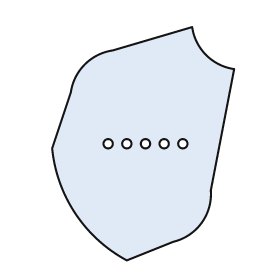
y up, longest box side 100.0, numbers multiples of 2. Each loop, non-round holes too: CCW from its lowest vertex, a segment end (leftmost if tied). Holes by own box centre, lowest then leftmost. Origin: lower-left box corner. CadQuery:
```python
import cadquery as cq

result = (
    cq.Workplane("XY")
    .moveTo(32.0, 0.0)
    .lineTo(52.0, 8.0)
    .threePointArc((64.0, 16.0), (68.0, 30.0))
    .lineTo(78.0, 82.0)
    .threePointArc((66.0, 88.0), (60.0, 100.0))
    .lineTo(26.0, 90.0)
    .threePointArc((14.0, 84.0), (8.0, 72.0))
    .lineTo(0.0, 48.0)
    .threePointArc((10.0, 20.0), (32.0, 0.0))
    .close()
    .moveTo(24.0, 50.0)
    .circle(2.0)
    .moveTo(32.0, 50.0)
    .circle(2.0)
    .moveTo(40.0, 50.0)
    .circle(2.0)
    .moveTo(48.0, 50.0)
    .circle(2.0)
    .moveTo(56.0, 50.0)
    .circle(2.0)
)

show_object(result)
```